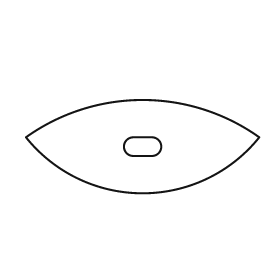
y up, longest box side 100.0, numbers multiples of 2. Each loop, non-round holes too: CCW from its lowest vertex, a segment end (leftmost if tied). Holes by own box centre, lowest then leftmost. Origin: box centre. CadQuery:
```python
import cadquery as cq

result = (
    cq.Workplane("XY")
    .moveTo(-50.0, 4.0)
    .threePointArc((0.0, -20.0), (50.0, 4.0))
    .threePointArc((0.0, 20.0), (-50.0, 4.0))
    .close()
    .moveTo(-4.0, -4.0)
    .lineTo(4.0, -4.0)
    .threePointArc((8.0, 0.0), (4.0, 4.0))
    .lineTo(-4.0, 4.0)
    .threePointArc((-8.0, 0.0), (-4.0, -4.0))
    .close()
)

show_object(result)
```